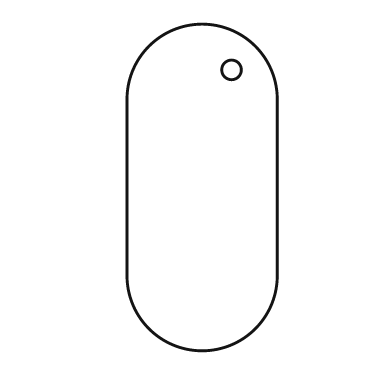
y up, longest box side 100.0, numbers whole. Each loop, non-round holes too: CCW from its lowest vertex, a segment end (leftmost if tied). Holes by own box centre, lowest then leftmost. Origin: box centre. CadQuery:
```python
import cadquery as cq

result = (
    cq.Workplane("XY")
    .moveTo(-23.0, -27.0)
    .threePointArc((0.0, -50.0), (23.0, -27.0))
    .lineTo(23.0, 27.0)
    .threePointArc((0.0, 50.0), (-23.0, 27.0))
    .close()
    .moveTo(9.0, 36.0)
    .circle(3.0)
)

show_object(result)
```